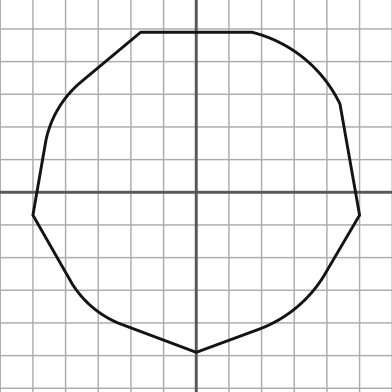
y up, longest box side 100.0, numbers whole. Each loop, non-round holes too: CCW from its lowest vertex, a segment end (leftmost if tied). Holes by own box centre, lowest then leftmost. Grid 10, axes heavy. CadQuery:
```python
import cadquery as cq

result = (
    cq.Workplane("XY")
    .moveTo(0.0, -49.0)
    .lineTo(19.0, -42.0)
    .threePointArc((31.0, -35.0), (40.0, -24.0))
    .lineTo(50.0, -7.0)
    .lineTo(44.0, 27.0)
    .threePointArc((33.0, 41.0), (17.0, 49.0))
    .lineTo(-17.0, 49.0)
    .lineTo(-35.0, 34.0)
    .threePointArc((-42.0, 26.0), (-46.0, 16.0))
    .lineTo(-50.0, -7.0)
    .lineTo(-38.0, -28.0)
    .threePointArc((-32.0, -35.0), (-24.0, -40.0))
    .close()
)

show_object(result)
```